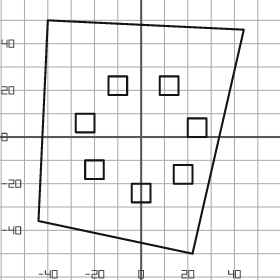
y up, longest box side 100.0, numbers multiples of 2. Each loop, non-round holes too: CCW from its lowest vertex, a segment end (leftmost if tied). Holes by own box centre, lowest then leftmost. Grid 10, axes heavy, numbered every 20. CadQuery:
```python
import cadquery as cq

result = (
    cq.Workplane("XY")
    .moveTo(22.0, -50.0)
    .lineTo(44.0, 46.0)
    .lineTo(-40.0, 50.0)
    .lineTo(-44.0, -36.0)
    .close()
    .moveTo(-4.0, -28.0)
    .lineTo(4.0, -28.0)
    .lineTo(4.0, -20.0)
    .lineTo(-4.0, -20.0)
    .close()
    .moveTo(14.0, -20.0)
    .lineTo(22.0, -20.0)
    .lineTo(22.0, -12.0)
    .lineTo(14.0, -12.0)
    .close()
    .moveTo(-24.0, -18.0)
    .lineTo(-16.0, -18.0)
    .lineTo(-16.0, -10.0)
    .lineTo(-24.0, -10.0)
    .close()
    .moveTo(20.0, 0.0)
    .lineTo(28.0, 0.0)
    .lineTo(28.0, 8.0)
    .lineTo(20.0, 8.0)
    .close()
    .moveTo(-28.0, 2.0)
    .lineTo(-20.0, 2.0)
    .lineTo(-20.0, 10.0)
    .lineTo(-28.0, 10.0)
    .close()
    .moveTo(-14.0, 18.0)
    .lineTo(-6.0, 18.0)
    .lineTo(-6.0, 26.0)
    .lineTo(-14.0, 26.0)
    .close()
    .moveTo(8.0, 18.0)
    .lineTo(16.0, 18.0)
    .lineTo(16.0, 26.0)
    .lineTo(8.0, 26.0)
    .close()
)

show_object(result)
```